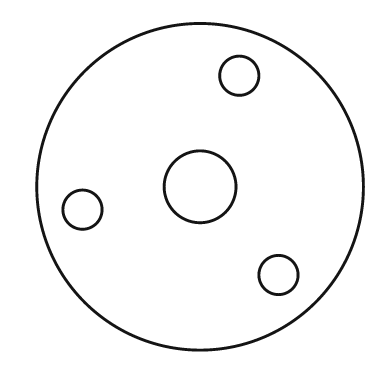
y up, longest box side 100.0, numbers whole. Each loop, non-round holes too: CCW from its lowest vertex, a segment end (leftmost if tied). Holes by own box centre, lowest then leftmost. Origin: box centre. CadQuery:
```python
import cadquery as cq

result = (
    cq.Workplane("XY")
    .moveTo(0.0, 0.0)
    .circle(50.0)
    .moveTo(24.0, -27.0)
    .circle(6.0)
    .moveTo(-36.0, -7.0)
    .circle(6.0)
    .moveTo(0.0, 0.0)
    .circle(11.0)
    .moveTo(12.0, 34.0)
    .circle(6.0)
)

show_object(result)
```